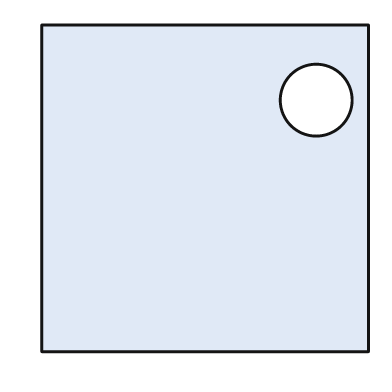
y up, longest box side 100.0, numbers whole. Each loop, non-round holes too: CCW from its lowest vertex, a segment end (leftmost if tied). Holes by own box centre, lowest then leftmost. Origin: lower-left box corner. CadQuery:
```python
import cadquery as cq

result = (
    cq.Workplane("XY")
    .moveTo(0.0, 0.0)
    .lineTo(100.0, 0.0)
    .lineTo(100.0, 100.0)
    .lineTo(0.0, 100.0)
    .close()
    .moveTo(84.0, 77.0)
    .circle(11.0)
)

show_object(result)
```